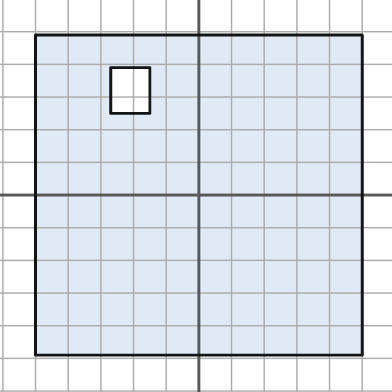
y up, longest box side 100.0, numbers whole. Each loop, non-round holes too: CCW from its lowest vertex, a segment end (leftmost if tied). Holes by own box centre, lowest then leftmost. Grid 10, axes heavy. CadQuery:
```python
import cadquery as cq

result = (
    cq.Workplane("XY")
    .moveTo(-50.0, -49.0)
    .lineTo(50.0, -49.0)
    .lineTo(50.0, 49.0)
    .lineTo(-50.0, 49.0)
    .close()
    .moveTo(-27.0, 25.0)
    .lineTo(-15.0, 25.0)
    .lineTo(-15.0, 39.0)
    .lineTo(-27.0, 39.0)
    .close()
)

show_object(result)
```